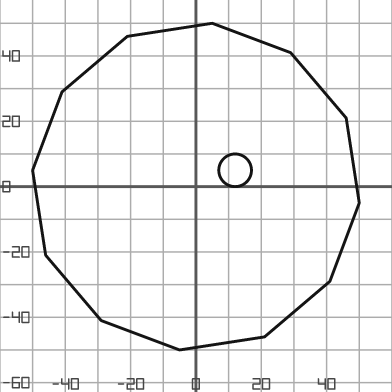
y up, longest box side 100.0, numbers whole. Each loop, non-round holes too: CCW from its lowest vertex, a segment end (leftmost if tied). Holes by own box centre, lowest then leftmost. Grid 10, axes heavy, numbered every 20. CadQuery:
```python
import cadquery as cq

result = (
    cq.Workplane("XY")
    .moveTo(-5.0, -50.0)
    .lineTo(21.0, -46.0)
    .lineTo(41.0, -29.0)
    .lineTo(50.0, -5.0)
    .lineTo(46.0, 21.0)
    .lineTo(29.0, 41.0)
    .lineTo(5.0, 50.0)
    .lineTo(-21.0, 46.0)
    .lineTo(-41.0, 29.0)
    .lineTo(-50.0, 5.0)
    .lineTo(-46.0, -21.0)
    .lineTo(-29.0, -41.0)
    .close()
    .moveTo(12.0, 5.0)
    .circle(5.0)
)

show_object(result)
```